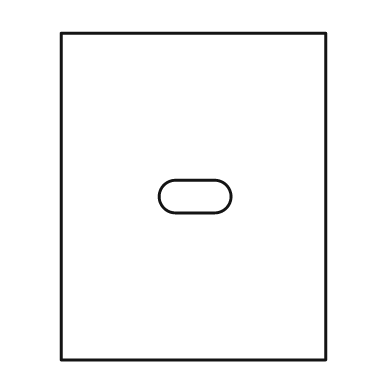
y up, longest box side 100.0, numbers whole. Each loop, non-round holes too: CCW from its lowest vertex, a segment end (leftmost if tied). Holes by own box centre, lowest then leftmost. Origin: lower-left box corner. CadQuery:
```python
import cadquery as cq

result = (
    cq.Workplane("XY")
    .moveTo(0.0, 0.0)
    .lineTo(81.0, 0.0)
    .lineTo(81.0, 100.0)
    .lineTo(0.0, 100.0)
    .close()
    .moveTo(35.0, 45.0)
    .lineTo(47.0, 45.0)
    .threePointArc((52.0, 50.0), (47.0, 55.0))
    .lineTo(35.0, 55.0)
    .threePointArc((30.0, 50.0), (35.0, 45.0))
    .close()
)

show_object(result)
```